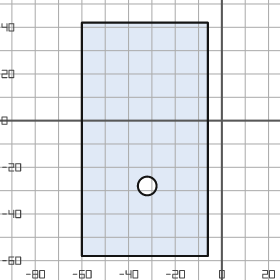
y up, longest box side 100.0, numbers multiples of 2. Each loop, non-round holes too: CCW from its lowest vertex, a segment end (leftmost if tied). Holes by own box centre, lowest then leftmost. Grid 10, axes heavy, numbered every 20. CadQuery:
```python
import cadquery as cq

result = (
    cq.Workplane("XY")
    .moveTo(-60.0, -58.0)
    .lineTo(-6.0, -58.0)
    .lineTo(-6.0, 42.0)
    .lineTo(-60.0, 42.0)
    .close()
    .moveTo(-32.0, -28.0)
    .circle(4.0)
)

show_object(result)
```